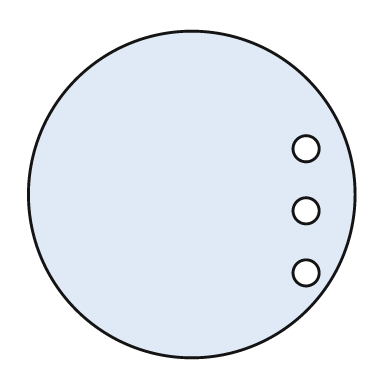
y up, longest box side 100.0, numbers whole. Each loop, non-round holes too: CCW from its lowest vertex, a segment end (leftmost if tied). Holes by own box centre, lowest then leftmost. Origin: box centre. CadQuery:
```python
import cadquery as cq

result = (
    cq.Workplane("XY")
    .moveTo(0.0, 0.0)
    .circle(50.0)
    .moveTo(35.0, -24.0)
    .circle(4.0)
    .moveTo(35.0, -5.0)
    .circle(4.0)
    .moveTo(35.0, 14.0)
    .circle(4.0)
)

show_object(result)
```